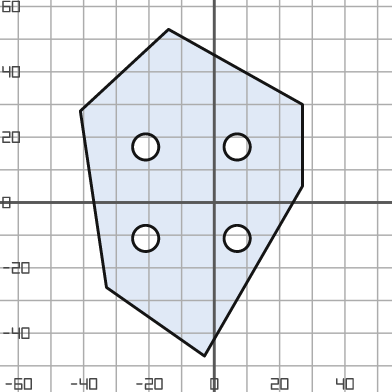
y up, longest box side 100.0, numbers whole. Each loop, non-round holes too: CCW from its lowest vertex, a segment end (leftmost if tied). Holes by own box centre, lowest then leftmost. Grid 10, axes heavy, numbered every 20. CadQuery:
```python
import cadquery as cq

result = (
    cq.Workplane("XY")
    .moveTo(-3.0, -47.0)
    .lineTo(27.0, 5.0)
    .lineTo(27.0, 30.0)
    .lineTo(-14.0, 53.0)
    .lineTo(-41.0, 28.0)
    .lineTo(-33.0, -26.0)
    .close()
    .moveTo(-21.0, -11.0)
    .circle(4.0)
    .moveTo(7.0, -11.0)
    .circle(4.0)
    .moveTo(-21.0, 17.0)
    .circle(4.0)
    .moveTo(7.0, 17.0)
    .circle(4.0)
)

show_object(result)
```